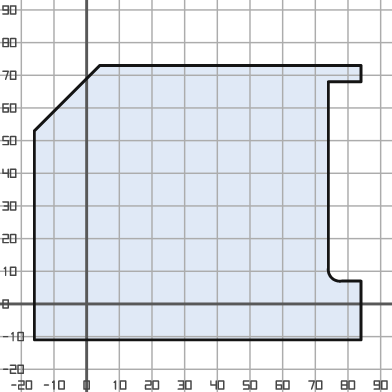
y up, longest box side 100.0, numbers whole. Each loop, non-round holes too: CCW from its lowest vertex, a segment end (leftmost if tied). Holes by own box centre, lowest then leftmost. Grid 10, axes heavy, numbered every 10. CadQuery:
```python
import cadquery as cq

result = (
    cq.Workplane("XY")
    .moveTo(-16.0, -11.0)
    .lineTo(84.0, -11.0)
    .lineTo(84.0, 7.0)
    .lineTo(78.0, 7.0)
    .threePointArc((75.0, 8.0), (74.0, 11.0))
    .lineTo(74.0, 68.0)
    .lineTo(84.0, 68.0)
    .lineTo(84.0, 73.0)
    .lineTo(4.0, 73.0)
    .lineTo(-16.0, 53.0)
    .close()
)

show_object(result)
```